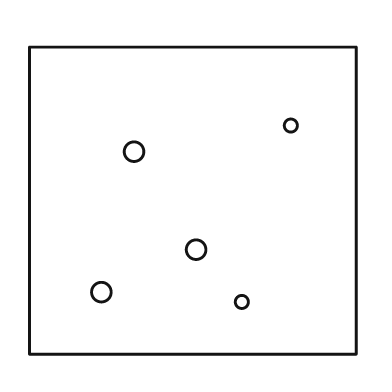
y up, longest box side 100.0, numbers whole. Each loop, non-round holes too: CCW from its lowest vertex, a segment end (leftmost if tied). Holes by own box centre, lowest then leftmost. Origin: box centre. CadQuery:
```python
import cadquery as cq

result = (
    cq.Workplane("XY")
    .moveTo(-50.0, -47.0)
    .lineTo(50.0, -47.0)
    .lineTo(50.0, 47.0)
    .lineTo(-50.0, 47.0)
    .close()
    .moveTo(15.0, -31.0)
    .circle(2.0)
    .moveTo(-28.0, -28.0)
    .circle(3.0)
    .moveTo(1.0, -15.0)
    .circle(3.0)
    .moveTo(-18.0, 15.0)
    .circle(3.0)
    .moveTo(30.0, 23.0)
    .circle(2.0)
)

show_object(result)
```